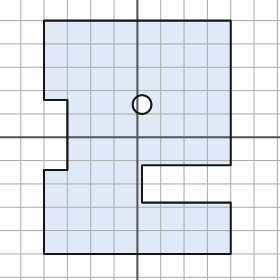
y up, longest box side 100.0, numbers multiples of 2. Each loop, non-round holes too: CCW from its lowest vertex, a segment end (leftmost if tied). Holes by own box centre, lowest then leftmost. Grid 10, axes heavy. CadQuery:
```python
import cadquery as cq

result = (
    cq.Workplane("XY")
    .moveTo(-40.0, -50.0)
    .lineTo(40.0, -50.0)
    .lineTo(40.0, -28.0)
    .lineTo(2.0, -28.0)
    .lineTo(2.0, -12.0)
    .lineTo(40.0, -12.0)
    .lineTo(40.0, 50.0)
    .lineTo(-40.0, 50.0)
    .lineTo(-40.0, 16.0)
    .lineTo(-30.0, 16.0)
    .lineTo(-30.0, -14.0)
    .lineTo(-40.0, -14.0)
    .close()
    .moveTo(2.0, 14.0)
    .circle(4.0)
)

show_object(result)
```